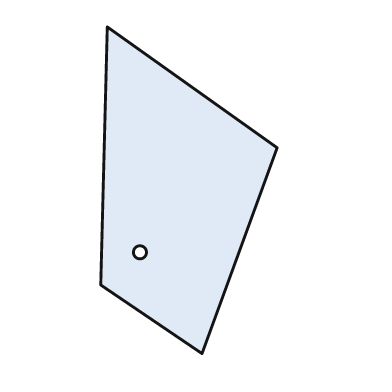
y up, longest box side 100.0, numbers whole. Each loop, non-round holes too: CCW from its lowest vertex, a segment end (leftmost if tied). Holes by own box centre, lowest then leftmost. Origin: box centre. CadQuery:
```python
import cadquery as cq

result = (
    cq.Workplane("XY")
    .moveTo(4.0, -50.0)
    .lineTo(27.0, 13.0)
    .lineTo(-25.0, 50.0)
    .lineTo(-27.0, -29.0)
    .close()
    .moveTo(-15.0, -19.0)
    .circle(2.0)
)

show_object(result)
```